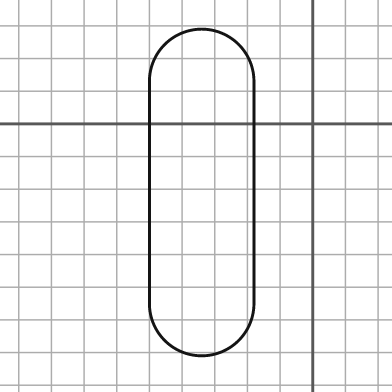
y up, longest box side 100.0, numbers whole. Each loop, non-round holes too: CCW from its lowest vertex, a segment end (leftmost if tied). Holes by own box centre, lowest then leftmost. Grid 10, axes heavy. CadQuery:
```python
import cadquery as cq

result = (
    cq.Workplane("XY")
    .moveTo(-50.0, -55.0)
    .threePointArc((-34.0, -71.0), (-18.0, -55.0))
    .lineTo(-18.0, 13.0)
    .threePointArc((-34.0, 29.0), (-50.0, 13.0))
    .close()
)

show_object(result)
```